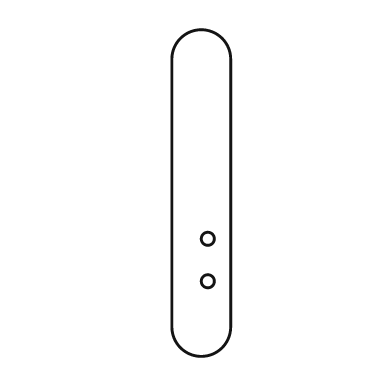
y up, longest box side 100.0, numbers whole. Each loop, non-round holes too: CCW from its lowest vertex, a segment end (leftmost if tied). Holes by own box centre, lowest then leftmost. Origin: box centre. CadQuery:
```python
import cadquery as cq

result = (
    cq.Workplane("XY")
    .moveTo(-9.0, -41.0)
    .threePointArc((0.0, -50.0), (9.0, -41.0))
    .lineTo(9.0, 41.0)
    .threePointArc((0.0, 50.0), (-9.0, 41.0))
    .close()
    .moveTo(2.0, -27.0)
    .circle(2.0)
    .moveTo(2.0, -14.0)
    .circle(2.0)
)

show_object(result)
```